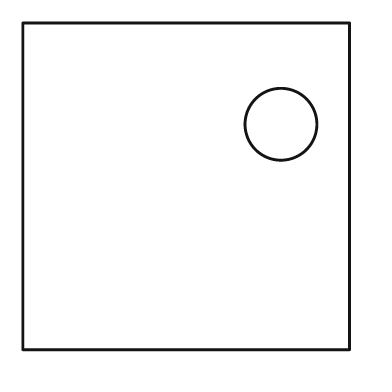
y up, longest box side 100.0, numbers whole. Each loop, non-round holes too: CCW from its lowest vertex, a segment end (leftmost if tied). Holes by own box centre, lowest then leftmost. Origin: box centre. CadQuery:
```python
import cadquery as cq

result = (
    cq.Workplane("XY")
    .moveTo(-50.0, -50.0)
    .lineTo(50.0, -50.0)
    .lineTo(50.0, 50.0)
    .lineTo(-50.0, 50.0)
    .close()
    .moveTo(29.0, 19.0)
    .circle(11.0)
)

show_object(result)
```